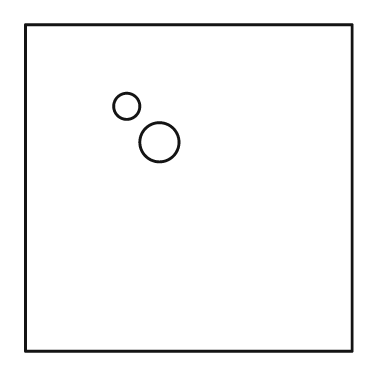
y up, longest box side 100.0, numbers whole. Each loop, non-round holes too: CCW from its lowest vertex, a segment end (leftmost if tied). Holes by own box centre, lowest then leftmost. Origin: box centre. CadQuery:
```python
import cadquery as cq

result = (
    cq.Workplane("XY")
    .moveTo(-50.0, -50.0)
    .lineTo(50.0, -50.0)
    .lineTo(50.0, 50.0)
    .lineTo(-50.0, 50.0)
    .close()
    .moveTo(-9.0, 14.0)
    .circle(6.0)
    .moveTo(-19.0, 25.0)
    .circle(4.0)
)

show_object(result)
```